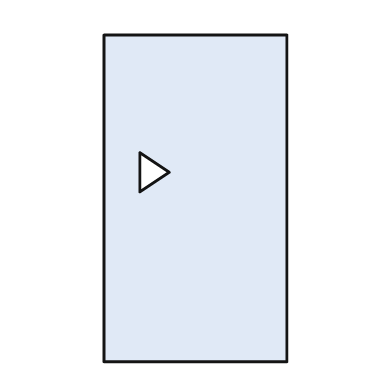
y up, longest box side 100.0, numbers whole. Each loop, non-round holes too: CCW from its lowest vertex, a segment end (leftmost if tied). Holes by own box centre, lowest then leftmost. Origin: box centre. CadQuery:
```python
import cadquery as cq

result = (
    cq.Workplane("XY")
    .moveTo(-28.0, -50.0)
    .lineTo(28.0, -50.0)
    .lineTo(28.0, 50.0)
    .lineTo(-28.0, 50.0)
    .close()
    .moveTo(-17.0, 2.0)
    .lineTo(-8.0, 8.0)
    .lineTo(-17.0, 14.0)
    .close()
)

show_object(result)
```